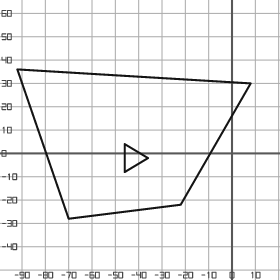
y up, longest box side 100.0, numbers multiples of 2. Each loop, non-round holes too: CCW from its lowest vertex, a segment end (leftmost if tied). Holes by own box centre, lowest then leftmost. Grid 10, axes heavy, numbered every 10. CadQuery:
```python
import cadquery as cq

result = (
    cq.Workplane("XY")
    .moveTo(-70.0, -28.0)
    .lineTo(-22.0, -22.0)
    .lineTo(8.0, 30.0)
    .lineTo(-92.0, 36.0)
    .close()
    .moveTo(-46.0, -8.0)
    .lineTo(-36.0, -2.0)
    .lineTo(-46.0, 4.0)
    .close()
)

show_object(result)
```